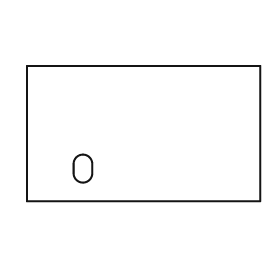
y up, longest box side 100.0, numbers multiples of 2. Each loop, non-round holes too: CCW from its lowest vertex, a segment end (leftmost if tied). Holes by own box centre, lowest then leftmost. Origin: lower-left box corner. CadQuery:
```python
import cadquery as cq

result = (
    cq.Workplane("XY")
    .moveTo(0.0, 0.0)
    .lineTo(100.0, 0.0)
    .lineTo(100.0, 58.0)
    .lineTo(0.0, 58.0)
    .close()
    .moveTo(20.0, 12.0)
    .threePointArc((24.0, 8.0), (28.0, 12.0))
    .lineTo(28.0, 16.0)
    .threePointArc((24.0, 20.0), (20.0, 16.0))
    .close()
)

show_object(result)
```